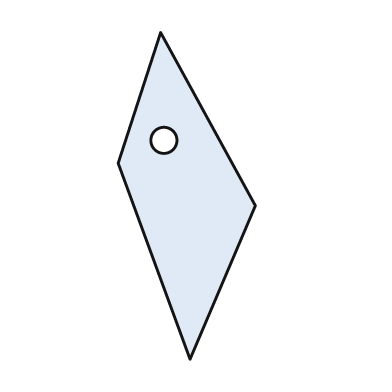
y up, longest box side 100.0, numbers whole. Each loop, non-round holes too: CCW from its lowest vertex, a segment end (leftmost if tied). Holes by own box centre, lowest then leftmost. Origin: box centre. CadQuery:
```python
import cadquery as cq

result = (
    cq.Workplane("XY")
    .moveTo(1.0, -50.0)
    .lineTo(21.0, -3.0)
    .lineTo(-8.0, 50.0)
    .lineTo(-21.0, 10.0)
    .close()
    .moveTo(-7.0, 17.0)
    .circle(4.0)
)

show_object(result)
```